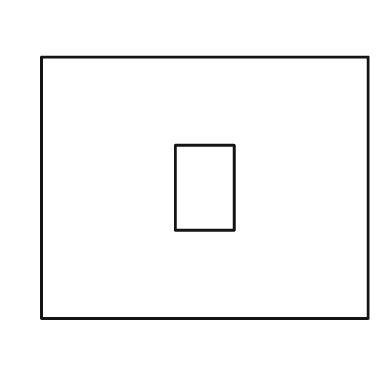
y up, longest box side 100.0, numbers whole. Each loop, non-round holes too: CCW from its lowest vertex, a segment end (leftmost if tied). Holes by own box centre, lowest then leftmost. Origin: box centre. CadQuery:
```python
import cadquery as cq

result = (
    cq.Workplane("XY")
    .moveTo(-50.0, -40.0)
    .lineTo(50.0, -40.0)
    .lineTo(50.0, 40.0)
    .lineTo(-50.0, 40.0)
    .close()
    .moveTo(-9.0, -13.0)
    .lineTo(9.0, -13.0)
    .lineTo(9.0, 13.0)
    .lineTo(-9.0, 13.0)
    .close()
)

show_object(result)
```